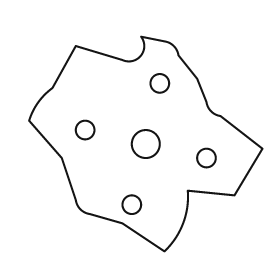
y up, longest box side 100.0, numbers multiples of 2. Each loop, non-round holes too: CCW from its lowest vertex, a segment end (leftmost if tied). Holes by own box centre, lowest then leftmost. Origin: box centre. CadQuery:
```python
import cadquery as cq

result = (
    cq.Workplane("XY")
    .moveTo(8.0, -46.0)
    .threePointArc((16.0, -34.0), (18.0, -20.0))
    .lineTo(38.0, -22.0)
    .lineTo(50.0, -2.0)
    .lineTo(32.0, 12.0)
    .threePointArc((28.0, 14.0), (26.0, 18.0))
    .lineTo(22.0, 28.0)
    .lineTo(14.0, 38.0)
    .threePointArc((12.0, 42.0), (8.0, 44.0))
    .lineTo(-2.0, 46.0)
    .threePointArc((-2.0, 38.0), (-10.0, 36.0))
    .lineTo(-30.0, 42.0)
    .lineTo(-40.0, 24.0)
    .threePointArc((-46.0, 18.0), (-50.0, 10.0))
    .lineTo(-36.0, -6.0)
    .lineTo(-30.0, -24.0)
    .threePointArc((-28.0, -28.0), (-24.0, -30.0))
    .lineTo(-10.0, -34.0)
    .close()
    .moveTo(-6.0, -26.0)
    .circle(4.0)
    .moveTo(26.0, -6.0)
    .circle(4.0)
    .moveTo(0.0, 0.0)
    .circle(6.0)
    .moveTo(-26.0, 6.0)
    .circle(4.0)
    .moveTo(6.0, 26.0)
    .circle(4.0)
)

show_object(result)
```